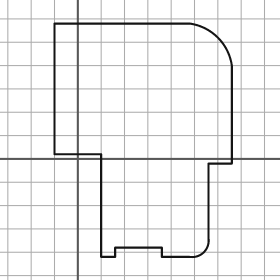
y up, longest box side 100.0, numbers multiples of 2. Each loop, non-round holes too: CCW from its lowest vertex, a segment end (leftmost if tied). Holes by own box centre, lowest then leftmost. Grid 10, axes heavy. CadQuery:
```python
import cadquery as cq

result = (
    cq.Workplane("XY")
    .moveTo(10.0, -42.0)
    .lineTo(16.0, -42.0)
    .lineTo(16.0, -38.0)
    .lineTo(36.0, -38.0)
    .lineTo(36.0, -42.0)
    .lineTo(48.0, -42.0)
    .threePointArc((54.0, -40.0), (56.0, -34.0))
    .lineTo(56.0, -2.0)
    .lineTo(66.0, -2.0)
    .lineTo(66.0, 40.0)
    .threePointArc((60.0, 52.0), (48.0, 58.0))
    .lineTo(-10.0, 58.0)
    .lineTo(-10.0, 2.0)
    .lineTo(10.0, 2.0)
    .close()
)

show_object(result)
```